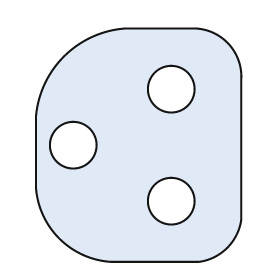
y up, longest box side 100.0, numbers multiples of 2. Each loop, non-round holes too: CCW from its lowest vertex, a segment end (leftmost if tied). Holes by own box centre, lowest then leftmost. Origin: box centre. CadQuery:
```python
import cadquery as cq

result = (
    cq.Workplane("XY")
    .moveTo(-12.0, -50.0)
    .lineTo(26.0, -50.0)
    .threePointArc((38.0, -44.0), (44.0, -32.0))
    .lineTo(44.0, 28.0)
    .threePointArc((38.0, 44.0), (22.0, 50.0))
    .lineTo(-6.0, 50.0)
    .threePointArc((-32.0, 38.0), (-44.0, 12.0))
    .lineTo(-44.0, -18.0)
    .threePointArc((-34.0, -40.0), (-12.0, -50.0))
    .close()
    .moveTo(14.0, -24.0)
    .circle(10.0)
    .moveTo(-28.0, 0.0)
    .circle(10.0)
    .moveTo(14.0, 24.0)
    .circle(10.0)
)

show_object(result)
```